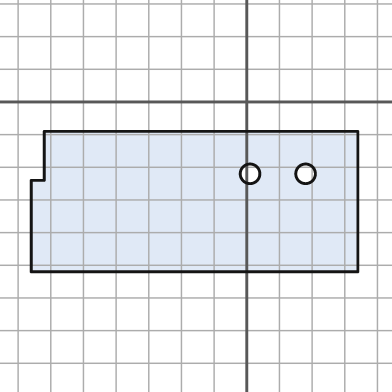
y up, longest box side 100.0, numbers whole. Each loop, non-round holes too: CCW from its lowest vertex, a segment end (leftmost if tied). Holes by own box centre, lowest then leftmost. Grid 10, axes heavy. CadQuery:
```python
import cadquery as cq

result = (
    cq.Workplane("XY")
    .moveTo(-66.0, -52.0)
    .lineTo(34.0, -52.0)
    .lineTo(34.0, -9.0)
    .lineTo(-62.0, -9.0)
    .lineTo(-62.0, -24.0)
    .lineTo(-66.0, -24.0)
    .close()
    .moveTo(1.0, -22.0)
    .circle(3.0)
    .moveTo(18.0, -22.0)
    .circle(3.0)
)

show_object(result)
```